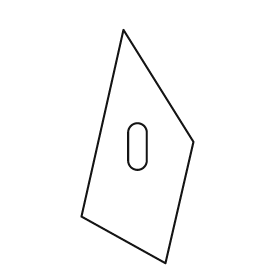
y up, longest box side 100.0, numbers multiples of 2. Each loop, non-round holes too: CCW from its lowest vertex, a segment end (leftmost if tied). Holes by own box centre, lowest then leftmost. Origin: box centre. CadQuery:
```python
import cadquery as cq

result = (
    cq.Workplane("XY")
    .moveTo(12.0, -50.0)
    .lineTo(24.0, 2.0)
    .lineTo(-6.0, 50.0)
    .lineTo(-24.0, -30.0)
    .close()
    .moveTo(-4.0, -6.0)
    .threePointArc((0.0, -10.0), (4.0, -6.0))
    .lineTo(4.0, 6.0)
    .threePointArc((0.0, 10.0), (-4.0, 6.0))
    .close()
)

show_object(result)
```